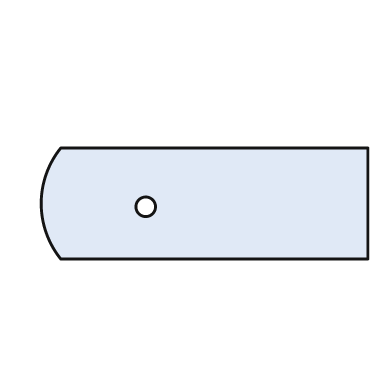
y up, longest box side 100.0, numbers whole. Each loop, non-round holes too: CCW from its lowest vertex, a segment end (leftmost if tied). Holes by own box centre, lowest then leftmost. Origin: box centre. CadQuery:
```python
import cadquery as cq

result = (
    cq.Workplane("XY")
    .moveTo(-44.0, -17.0)
    .lineTo(50.0, -17.0)
    .lineTo(50.0, 17.0)
    .lineTo(-44.0, 17.0)
    .threePointArc((-50.0, 0.0), (-44.0, -17.0))
    .close()
    .moveTo(-18.0, -1.0)
    .circle(3.0)
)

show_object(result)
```